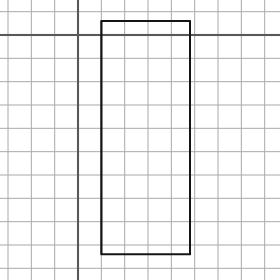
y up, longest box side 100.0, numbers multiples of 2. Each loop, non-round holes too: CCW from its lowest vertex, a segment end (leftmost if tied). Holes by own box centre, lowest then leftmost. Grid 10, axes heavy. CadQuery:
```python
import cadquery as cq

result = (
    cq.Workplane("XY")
    .moveTo(10.0, -94.0)
    .lineTo(48.0, -94.0)
    .lineTo(48.0, 6.0)
    .lineTo(10.0, 6.0)
    .close()
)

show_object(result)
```